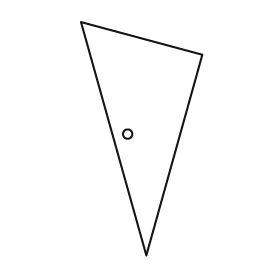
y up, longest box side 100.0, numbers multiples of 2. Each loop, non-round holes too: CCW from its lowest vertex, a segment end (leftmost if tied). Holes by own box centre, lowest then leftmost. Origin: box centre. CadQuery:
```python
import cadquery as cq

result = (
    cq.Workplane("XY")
    .moveTo(2.0, -50.0)
    .lineTo(26.0, 36.0)
    .lineTo(-26.0, 50.0)
    .close()
    .moveTo(-6.0, 2.0)
    .circle(2.0)
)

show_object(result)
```